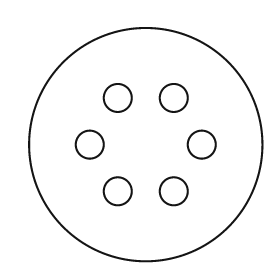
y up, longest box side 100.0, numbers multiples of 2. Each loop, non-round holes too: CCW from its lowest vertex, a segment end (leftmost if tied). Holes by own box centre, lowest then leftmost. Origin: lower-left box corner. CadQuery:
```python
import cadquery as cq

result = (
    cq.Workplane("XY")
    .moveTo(50.0, 50.0)
    .circle(50.0)
    .moveTo(38.0, 30.0)
    .circle(6.0)
    .moveTo(62.0, 30.0)
    .circle(6.0)
    .moveTo(26.0, 50.0)
    .circle(6.0)
    .moveTo(74.0, 50.0)
    .circle(6.0)
    .moveTo(38.0, 70.0)
    .circle(6.0)
    .moveTo(62.0, 70.0)
    .circle(6.0)
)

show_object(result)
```